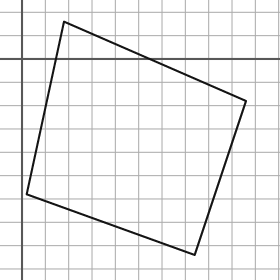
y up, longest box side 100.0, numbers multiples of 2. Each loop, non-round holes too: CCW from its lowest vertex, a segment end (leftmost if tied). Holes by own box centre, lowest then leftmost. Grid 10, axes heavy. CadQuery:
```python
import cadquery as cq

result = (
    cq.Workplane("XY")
    .moveTo(74.0, -84.0)
    .lineTo(96.0, -18.0)
    .lineTo(18.0, 16.0)
    .lineTo(2.0, -58.0)
    .close()
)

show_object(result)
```